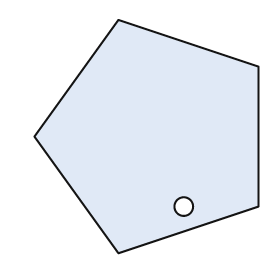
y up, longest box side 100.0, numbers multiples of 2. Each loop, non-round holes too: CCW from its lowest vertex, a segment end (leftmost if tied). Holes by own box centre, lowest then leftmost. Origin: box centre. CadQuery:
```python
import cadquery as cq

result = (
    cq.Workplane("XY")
    .moveTo(-12.0, -50.0)
    .lineTo(48.0, -30.0)
    .lineTo(48.0, 30.0)
    .lineTo(-12.0, 50.0)
    .lineTo(-48.0, 0.0)
    .close()
    .moveTo(16.0, -30.0)
    .circle(4.0)
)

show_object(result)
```